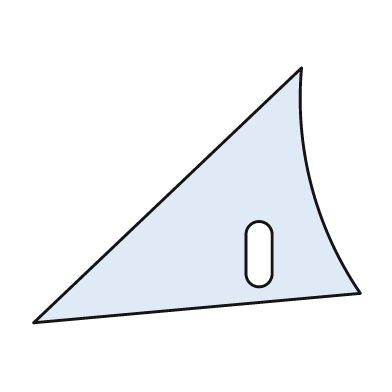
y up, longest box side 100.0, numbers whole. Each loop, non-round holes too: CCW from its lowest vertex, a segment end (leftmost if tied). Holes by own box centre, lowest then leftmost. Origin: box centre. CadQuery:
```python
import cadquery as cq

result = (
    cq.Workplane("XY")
    .moveTo(-50.0, -39.0)
    .lineTo(50.0, -30.0)
    .threePointArc((35.0, 3.0), (32.0, 39.0))
    .close()
    .moveTo(15.0, -24.0)
    .threePointArc((19.0, -28.0), (23.0, -24.0))
    .lineTo(23.0, -12.0)
    .threePointArc((19.0, -8.0), (15.0, -12.0))
    .close()
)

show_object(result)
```